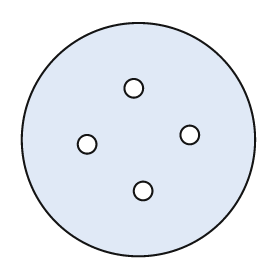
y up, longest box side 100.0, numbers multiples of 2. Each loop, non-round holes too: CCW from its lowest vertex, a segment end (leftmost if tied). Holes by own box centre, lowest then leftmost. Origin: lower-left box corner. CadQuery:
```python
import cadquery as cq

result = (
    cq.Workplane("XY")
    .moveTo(50.0, 50.0)
    .circle(50.0)
    .moveTo(52.0, 28.0)
    .circle(4.0)
    .moveTo(28.0, 48.0)
    .circle(4.0)
    .moveTo(72.0, 52.0)
    .circle(4.0)
    .moveTo(48.0, 72.0)
    .circle(4.0)
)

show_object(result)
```